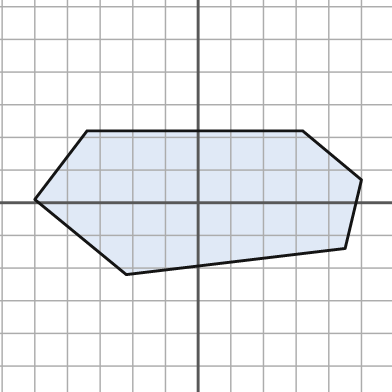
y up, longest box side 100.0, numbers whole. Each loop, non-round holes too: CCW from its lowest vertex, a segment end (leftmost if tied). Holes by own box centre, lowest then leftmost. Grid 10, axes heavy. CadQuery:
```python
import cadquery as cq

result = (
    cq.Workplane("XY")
    .moveTo(-22.0, -22.0)
    .lineTo(45.0, -14.0)
    .lineTo(50.0, 7.0)
    .lineTo(32.0, 22.0)
    .lineTo(-34.0, 22.0)
    .lineTo(-50.0, 1.0)
    .close()
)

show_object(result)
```